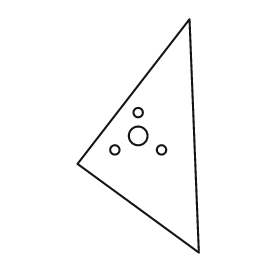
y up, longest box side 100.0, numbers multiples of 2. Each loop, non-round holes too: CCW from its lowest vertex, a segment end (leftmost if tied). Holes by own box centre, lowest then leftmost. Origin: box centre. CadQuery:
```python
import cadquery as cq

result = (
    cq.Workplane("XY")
    .moveTo(26.0, -50.0)
    .lineTo(22.0, 50.0)
    .lineTo(-26.0, -12.0)
    .close()
    .moveTo(-10.0, -6.0)
    .circle(2.0)
    .moveTo(10.0, -6.0)
    .circle(2.0)
    .moveTo(0.0, 0.0)
    .circle(4.0)
    .moveTo(0.0, 10.0)
    .circle(2.0)
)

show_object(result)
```